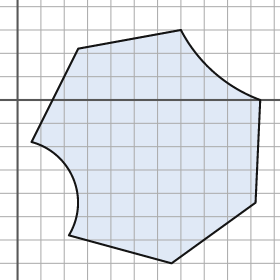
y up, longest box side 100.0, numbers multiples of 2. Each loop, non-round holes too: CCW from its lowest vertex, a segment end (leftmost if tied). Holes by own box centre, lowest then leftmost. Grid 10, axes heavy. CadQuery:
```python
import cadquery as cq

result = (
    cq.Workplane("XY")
    .moveTo(66.0, -70.0)
    .lineTo(102.0, -44.0)
    .lineTo(104.0, 0.0)
    .threePointArc((84.0, 12.0), (70.0, 30.0))
    .lineTo(26.0, 22.0)
    .lineTo(6.0, -18.0)
    .threePointArc((24.0, -34.0), (22.0, -58.0))
    .close()
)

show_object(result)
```